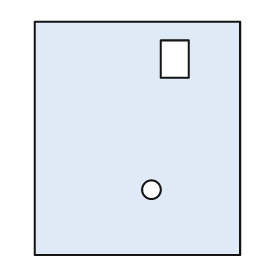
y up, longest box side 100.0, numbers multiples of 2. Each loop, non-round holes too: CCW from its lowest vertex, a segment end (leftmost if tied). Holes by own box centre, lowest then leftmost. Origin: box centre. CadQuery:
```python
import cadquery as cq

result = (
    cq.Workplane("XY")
    .moveTo(-44.0, -50.0)
    .lineTo(44.0, -50.0)
    .lineTo(44.0, 50.0)
    .lineTo(-44.0, 50.0)
    .close()
    .moveTo(6.0, -22.0)
    .circle(4.0)
    .moveTo(10.0, 26.0)
    .lineTo(22.0, 26.0)
    .lineTo(22.0, 42.0)
    .lineTo(10.0, 42.0)
    .close()
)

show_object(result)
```